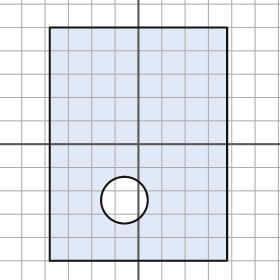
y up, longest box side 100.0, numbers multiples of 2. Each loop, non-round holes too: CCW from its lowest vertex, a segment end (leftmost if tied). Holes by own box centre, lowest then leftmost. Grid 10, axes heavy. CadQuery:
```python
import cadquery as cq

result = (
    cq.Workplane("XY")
    .moveTo(-38.0, -50.0)
    .lineTo(38.0, -50.0)
    .lineTo(38.0, 50.0)
    .lineTo(-38.0, 50.0)
    .close()
    .moveTo(-6.0, -24.0)
    .circle(10.0)
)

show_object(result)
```